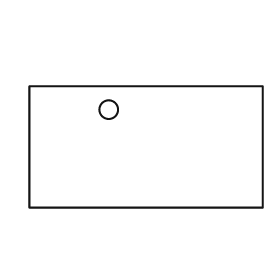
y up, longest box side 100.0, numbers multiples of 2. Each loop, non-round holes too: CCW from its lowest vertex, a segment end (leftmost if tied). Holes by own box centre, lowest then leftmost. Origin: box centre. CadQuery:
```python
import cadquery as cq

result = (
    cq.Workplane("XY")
    .moveTo(-50.0, -26.0)
    .lineTo(50.0, -26.0)
    .lineTo(50.0, 26.0)
    .lineTo(-50.0, 26.0)
    .close()
    .moveTo(-16.0, 16.0)
    .circle(4.0)
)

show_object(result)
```